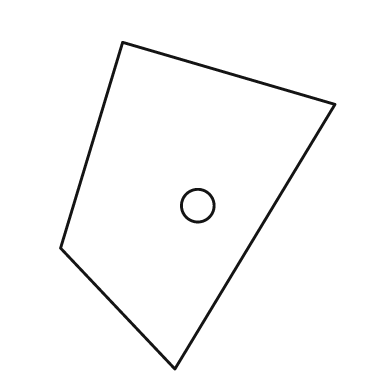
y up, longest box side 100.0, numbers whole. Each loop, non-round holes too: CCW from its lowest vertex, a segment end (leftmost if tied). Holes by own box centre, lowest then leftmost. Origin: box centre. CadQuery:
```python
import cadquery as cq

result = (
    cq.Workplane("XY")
    .moveTo(-7.0, -50.0)
    .lineTo(42.0, 31.0)
    .lineTo(-23.0, 50.0)
    .lineTo(-42.0, -13.0)
    .close()
    .moveTo(0.0, 0.0)
    .circle(5.0)
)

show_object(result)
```